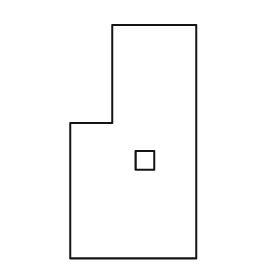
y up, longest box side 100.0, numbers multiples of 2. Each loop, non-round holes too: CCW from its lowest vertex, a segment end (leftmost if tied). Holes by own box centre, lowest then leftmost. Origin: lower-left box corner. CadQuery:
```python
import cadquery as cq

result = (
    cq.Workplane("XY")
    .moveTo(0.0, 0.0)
    .lineTo(54.0, 0.0)
    .lineTo(54.0, 100.0)
    .lineTo(18.0, 100.0)
    .lineTo(18.0, 58.0)
    .lineTo(0.0, 58.0)
    .close()
    .moveTo(28.0, 38.0)
    .lineTo(36.0, 38.0)
    .lineTo(36.0, 46.0)
    .lineTo(28.0, 46.0)
    .close()
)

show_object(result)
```